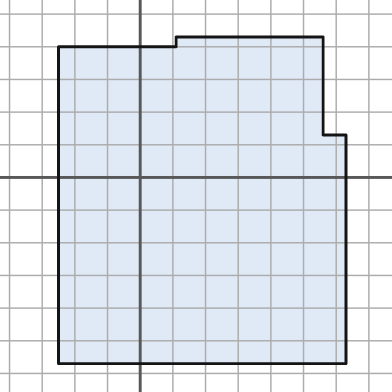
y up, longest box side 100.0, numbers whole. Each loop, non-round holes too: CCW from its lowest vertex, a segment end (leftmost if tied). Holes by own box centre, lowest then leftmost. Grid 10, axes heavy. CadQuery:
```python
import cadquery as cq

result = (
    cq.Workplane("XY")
    .moveTo(-25.0, -57.0)
    .lineTo(63.0, -57.0)
    .lineTo(63.0, 13.0)
    .lineTo(56.0, 13.0)
    .lineTo(56.0, 43.0)
    .lineTo(11.0, 43.0)
    .lineTo(11.0, 40.0)
    .lineTo(-25.0, 40.0)
    .close()
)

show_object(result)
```